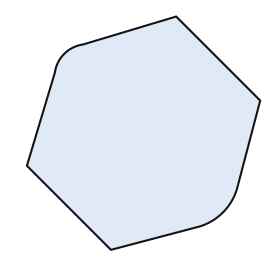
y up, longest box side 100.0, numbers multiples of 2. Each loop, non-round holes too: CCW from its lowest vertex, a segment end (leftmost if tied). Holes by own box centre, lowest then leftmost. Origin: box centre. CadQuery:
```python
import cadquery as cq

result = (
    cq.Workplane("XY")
    .moveTo(-14.0, -50.0)
    .lineTo(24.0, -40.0)
    .threePointArc((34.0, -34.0), (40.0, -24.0))
    .lineTo(50.0, 14.0)
    .lineTo(14.0, 50.0)
    .lineTo(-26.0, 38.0)
    .threePointArc((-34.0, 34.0), (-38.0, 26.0))
    .lineTo(-50.0, -14.0)
    .close()
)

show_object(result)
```